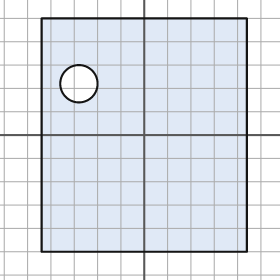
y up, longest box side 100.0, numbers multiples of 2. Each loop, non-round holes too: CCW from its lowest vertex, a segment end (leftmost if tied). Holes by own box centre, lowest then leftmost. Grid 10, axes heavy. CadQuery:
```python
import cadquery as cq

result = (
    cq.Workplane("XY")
    .moveTo(-44.0, -50.0)
    .lineTo(44.0, -50.0)
    .lineTo(44.0, 50.0)
    .lineTo(-44.0, 50.0)
    .close()
    .moveTo(-28.0, 22.0)
    .circle(8.0)
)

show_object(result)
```